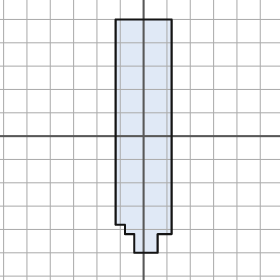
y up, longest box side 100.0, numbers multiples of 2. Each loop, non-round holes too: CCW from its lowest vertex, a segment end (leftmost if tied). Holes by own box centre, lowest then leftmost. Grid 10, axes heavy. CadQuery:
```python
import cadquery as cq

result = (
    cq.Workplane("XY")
    .moveTo(-4.0, -50.0)
    .lineTo(6.0, -50.0)
    .lineTo(6.0, -42.0)
    .lineTo(12.0, -42.0)
    .lineTo(12.0, 50.0)
    .lineTo(-12.0, 50.0)
    .lineTo(-12.0, -38.0)
    .lineTo(-8.0, -38.0)
    .lineTo(-8.0, -42.0)
    .lineTo(-4.0, -42.0)
    .close()
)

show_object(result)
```